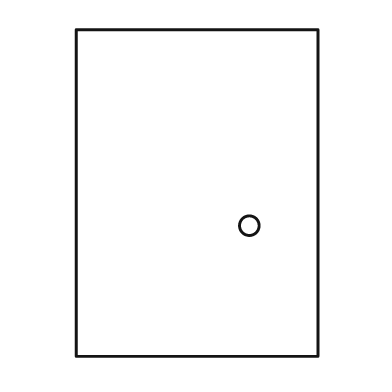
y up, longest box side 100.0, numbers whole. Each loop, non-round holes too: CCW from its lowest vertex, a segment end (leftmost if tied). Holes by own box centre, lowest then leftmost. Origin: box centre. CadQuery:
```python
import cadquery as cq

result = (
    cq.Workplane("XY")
    .moveTo(-37.0, -50.0)
    .lineTo(37.0, -50.0)
    .lineTo(37.0, 50.0)
    .lineTo(-37.0, 50.0)
    .close()
    .moveTo(16.0, -10.0)
    .circle(3.0)
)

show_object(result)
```